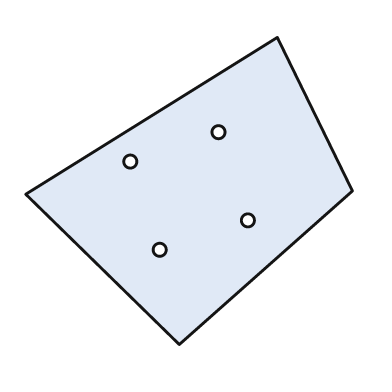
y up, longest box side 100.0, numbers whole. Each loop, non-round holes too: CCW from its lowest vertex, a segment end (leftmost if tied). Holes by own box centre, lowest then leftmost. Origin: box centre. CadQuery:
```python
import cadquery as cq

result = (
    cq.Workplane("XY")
    .moveTo(-3.0, -47.0)
    .lineTo(50.0, 0.0)
    .lineTo(27.0, 47.0)
    .lineTo(-50.0, -1.0)
    .close()
    .moveTo(-9.0, -18.0)
    .circle(2.0)
    .moveTo(18.0, -9.0)
    .circle(2.0)
    .moveTo(-18.0, 9.0)
    .circle(2.0)
    .moveTo(9.0, 18.0)
    .circle(2.0)
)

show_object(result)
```